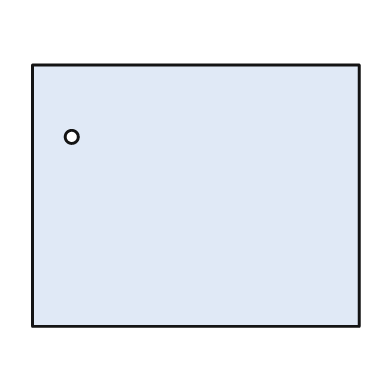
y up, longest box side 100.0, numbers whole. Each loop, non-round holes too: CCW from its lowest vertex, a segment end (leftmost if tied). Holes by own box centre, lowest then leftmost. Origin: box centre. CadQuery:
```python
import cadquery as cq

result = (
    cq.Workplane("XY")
    .moveTo(-50.0, -40.0)
    .lineTo(50.0, -40.0)
    .lineTo(50.0, 40.0)
    .lineTo(-50.0, 40.0)
    .close()
    .moveTo(-38.0, 18.0)
    .circle(2.0)
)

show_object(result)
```